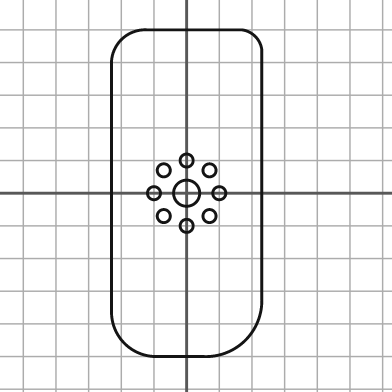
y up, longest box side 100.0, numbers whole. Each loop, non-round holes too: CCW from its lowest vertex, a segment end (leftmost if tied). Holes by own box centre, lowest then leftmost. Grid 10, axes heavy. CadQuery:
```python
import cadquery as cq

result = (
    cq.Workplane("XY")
    .moveTo(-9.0, -50.0)
    .lineTo(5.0, -50.0)
    .threePointArc((18.0, -45.0), (23.0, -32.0))
    .lineTo(23.0, 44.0)
    .threePointArc((21.0, 48.0), (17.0, 50.0))
    .lineTo(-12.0, 50.0)
    .threePointArc((-20.0, 47.0), (-23.0, 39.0))
    .lineTo(-23.0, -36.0)
    .threePointArc((-19.0, -46.0), (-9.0, -50.0))
    .close()
    .moveTo(0.0, -10.0)
    .circle(2.0)
    .moveTo(-7.0, -7.0)
    .circle(2.0)
    .moveTo(7.0, -7.0)
    .circle(2.0)
    .moveTo(-10.0, 0.0)
    .circle(2.0)
    .moveTo(0.0, 0.0)
    .circle(4.0)
    .moveTo(10.0, 0.0)
    .circle(2.0)
    .moveTo(-7.0, 7.0)
    .circle(2.0)
    .moveTo(7.0, 7.0)
    .circle(2.0)
    .moveTo(0.0, 10.0)
    .circle(2.0)
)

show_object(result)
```